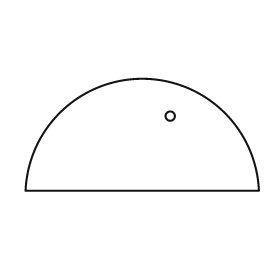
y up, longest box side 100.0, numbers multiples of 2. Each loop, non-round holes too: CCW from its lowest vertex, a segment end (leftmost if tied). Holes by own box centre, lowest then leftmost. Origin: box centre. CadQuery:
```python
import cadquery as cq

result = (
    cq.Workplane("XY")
    .moveTo(-50.0, -24.0)
    .lineTo(50.0, -24.0)
    .threePointArc((0.0, 24.0), (-50.0, -24.0))
    .close()
    .moveTo(12.0, 8.0)
    .circle(2.0)
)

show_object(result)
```